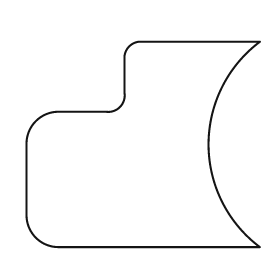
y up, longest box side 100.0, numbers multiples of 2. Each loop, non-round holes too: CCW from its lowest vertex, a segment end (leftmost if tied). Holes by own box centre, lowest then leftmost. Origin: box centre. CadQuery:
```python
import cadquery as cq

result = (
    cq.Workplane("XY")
    .moveTo(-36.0, -44.0)
    .lineTo(50.0, -44.0)
    .threePointArc((28.0, 0.0), (50.0, 44.0))
    .lineTo(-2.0, 44.0)
    .threePointArc((-6.0, 42.0), (-8.0, 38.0))
    .lineTo(-8.0, 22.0)
    .threePointArc((-10.0, 16.0), (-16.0, 14.0))
    .lineTo(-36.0, 14.0)
    .threePointArc((-46.0, 10.0), (-50.0, 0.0))
    .lineTo(-50.0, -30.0)
    .threePointArc((-46.0, -40.0), (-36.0, -44.0))
    .close()
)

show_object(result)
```